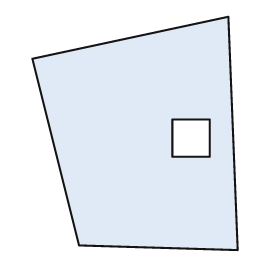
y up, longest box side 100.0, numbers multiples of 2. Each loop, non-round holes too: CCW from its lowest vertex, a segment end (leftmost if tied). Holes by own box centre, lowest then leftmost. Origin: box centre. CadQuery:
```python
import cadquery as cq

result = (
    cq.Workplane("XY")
    .moveTo(44.0, -50.0)
    .lineTo(40.0, 50.0)
    .lineTo(-44.0, 32.0)
    .lineTo(-24.0, -48.0)
    .close()
    .moveTo(16.0, -10.0)
    .lineTo(32.0, -10.0)
    .lineTo(32.0, 6.0)
    .lineTo(16.0, 6.0)
    .close()
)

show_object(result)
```